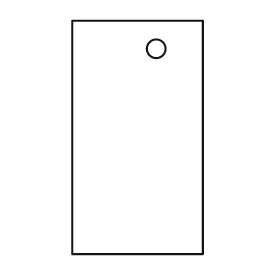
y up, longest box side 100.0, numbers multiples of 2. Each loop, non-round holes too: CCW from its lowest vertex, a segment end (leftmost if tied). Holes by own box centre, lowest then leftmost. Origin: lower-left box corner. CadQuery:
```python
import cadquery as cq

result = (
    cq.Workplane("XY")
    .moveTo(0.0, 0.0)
    .lineTo(56.0, 0.0)
    .lineTo(56.0, 100.0)
    .lineTo(0.0, 100.0)
    .close()
    .moveTo(36.0, 88.0)
    .circle(4.0)
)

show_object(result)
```